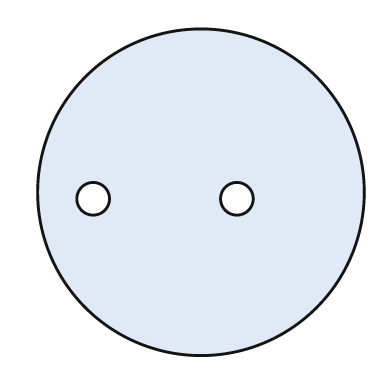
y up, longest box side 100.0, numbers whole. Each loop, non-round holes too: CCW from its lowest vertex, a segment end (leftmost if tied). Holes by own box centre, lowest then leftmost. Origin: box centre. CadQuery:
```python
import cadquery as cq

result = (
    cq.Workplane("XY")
    .moveTo(0.0, 0.0)
    .circle(50.0)
    .moveTo(-33.0, -2.0)
    .circle(5.0)
    .moveTo(11.0, -2.0)
    .circle(5.0)
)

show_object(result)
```